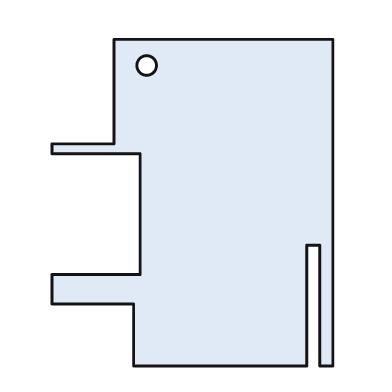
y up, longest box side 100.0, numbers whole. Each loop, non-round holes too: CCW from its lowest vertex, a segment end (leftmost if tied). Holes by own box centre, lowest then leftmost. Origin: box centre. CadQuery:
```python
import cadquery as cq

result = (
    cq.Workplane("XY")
    .moveTo(-18.0, -50.0)
    .lineTo(35.0, -50.0)
    .lineTo(35.0, -13.0)
    .lineTo(39.0, -13.0)
    .lineTo(39.0, -50.0)
    .lineTo(43.0, -50.0)
    .lineTo(43.0, 50.0)
    .lineTo(-24.0, 50.0)
    .lineTo(-24.0, 18.0)
    .lineTo(-43.0, 18.0)
    .lineTo(-43.0, 15.0)
    .lineTo(-16.0, 15.0)
    .lineTo(-16.0, -22.0)
    .lineTo(-43.0, -22.0)
    .lineTo(-43.0, -31.0)
    .lineTo(-18.0, -31.0)
    .close()
    .moveTo(-14.0, 42.0)
    .circle(3.0)
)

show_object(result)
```